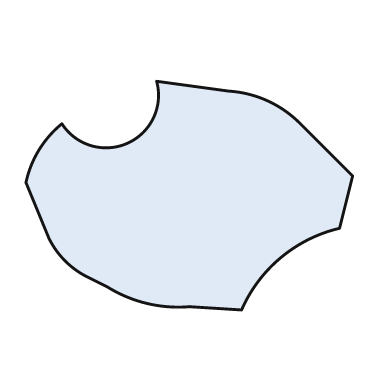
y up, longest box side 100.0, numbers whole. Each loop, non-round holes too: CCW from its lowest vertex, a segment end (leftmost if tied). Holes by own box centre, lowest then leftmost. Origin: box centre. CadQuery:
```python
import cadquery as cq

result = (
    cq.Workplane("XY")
    .moveTo(16.0, -35.0)
    .threePointArc((28.0, -19.0), (46.0, -10.0))
    .lineTo(50.0, 6.0)
    .lineTo(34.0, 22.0)
    .threePointArc((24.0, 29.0), (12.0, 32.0))
    .lineTo(-10.0, 35.0)
    .threePointArc((-19.0, 16.0), (-39.0, 22.0))
    .threePointArc((-46.0, 14.0), (-50.0, 4.0))
    .lineTo(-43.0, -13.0)
    .threePointArc((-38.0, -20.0), (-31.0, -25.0))
    .lineTo(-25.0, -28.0)
    .threePointArc((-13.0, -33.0), (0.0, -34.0))
    .close()
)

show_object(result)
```